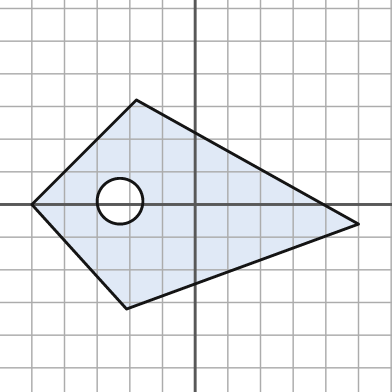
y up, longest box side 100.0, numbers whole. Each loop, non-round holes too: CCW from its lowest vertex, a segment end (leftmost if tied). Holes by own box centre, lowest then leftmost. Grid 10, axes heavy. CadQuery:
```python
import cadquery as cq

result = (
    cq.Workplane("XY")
    .moveTo(-21.0, -32.0)
    .lineTo(50.0, -6.0)
    .lineTo(-18.0, 32.0)
    .lineTo(-50.0, 0.0)
    .close()
    .moveTo(-23.0, 1.0)
    .circle(7.0)
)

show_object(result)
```